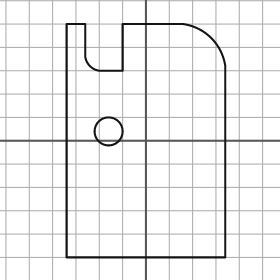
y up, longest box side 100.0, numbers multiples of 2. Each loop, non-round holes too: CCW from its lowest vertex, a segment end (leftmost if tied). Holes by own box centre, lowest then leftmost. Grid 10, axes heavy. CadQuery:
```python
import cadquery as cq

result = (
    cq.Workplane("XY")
    .moveTo(-34.0, -50.0)
    .lineTo(34.0, -50.0)
    .lineTo(34.0, 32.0)
    .threePointArc((28.0, 44.0), (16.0, 50.0))
    .lineTo(-10.0, 50.0)
    .lineTo(-10.0, 30.0)
    .lineTo(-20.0, 30.0)
    .threePointArc((-24.0, 32.0), (-26.0, 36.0))
    .lineTo(-26.0, 50.0)
    .lineTo(-34.0, 50.0)
    .close()
    .moveTo(-16.0, 4.0)
    .circle(6.0)
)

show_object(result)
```